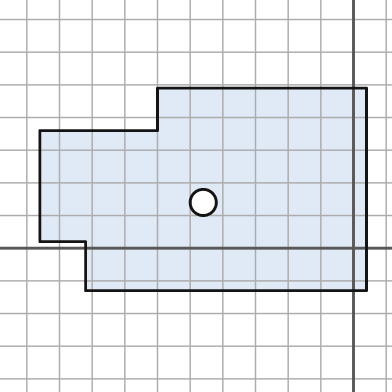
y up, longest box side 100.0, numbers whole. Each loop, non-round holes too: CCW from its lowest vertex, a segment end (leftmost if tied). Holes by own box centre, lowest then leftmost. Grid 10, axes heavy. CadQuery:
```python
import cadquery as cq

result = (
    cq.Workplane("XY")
    .moveTo(-82.0, -13.0)
    .lineTo(4.0, -13.0)
    .lineTo(4.0, 49.0)
    .lineTo(-60.0, 49.0)
    .lineTo(-60.0, 36.0)
    .lineTo(-96.0, 36.0)
    .lineTo(-96.0, 2.0)
    .lineTo(-82.0, 2.0)
    .close()
    .moveTo(-46.0, 14.0)
    .circle(4.0)
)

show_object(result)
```